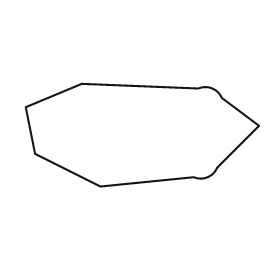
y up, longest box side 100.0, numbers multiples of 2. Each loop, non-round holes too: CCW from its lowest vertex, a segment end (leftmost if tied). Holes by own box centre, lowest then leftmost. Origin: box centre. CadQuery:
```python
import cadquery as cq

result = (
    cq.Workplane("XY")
    .moveTo(-18.0, -22.0)
    .lineTo(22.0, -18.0)
    .threePointArc((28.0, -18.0), (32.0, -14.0))
    .lineTo(50.0, 4.0)
    .lineTo(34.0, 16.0)
    .threePointArc((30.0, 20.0), (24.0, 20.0))
    .lineTo(-26.0, 22.0)
    .lineTo(-50.0, 12.0)
    .lineTo(-46.0, -8.0)
    .close()
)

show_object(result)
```